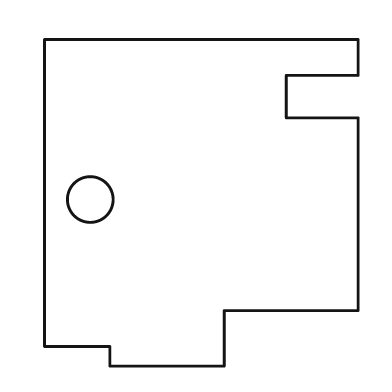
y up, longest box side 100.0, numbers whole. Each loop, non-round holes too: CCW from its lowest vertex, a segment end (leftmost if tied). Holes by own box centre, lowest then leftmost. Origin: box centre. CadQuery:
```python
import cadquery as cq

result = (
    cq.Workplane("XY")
    .moveTo(-28.0, -50.0)
    .lineTo(7.0, -50.0)
    .lineTo(7.0, -33.0)
    .lineTo(48.0, -33.0)
    .lineTo(48.0, 26.0)
    .lineTo(26.0, 26.0)
    .lineTo(26.0, 39.0)
    .lineTo(48.0, 39.0)
    .lineTo(48.0, 50.0)
    .lineTo(-48.0, 50.0)
    .lineTo(-48.0, -44.0)
    .lineTo(-28.0, -44.0)
    .close()
    .moveTo(-34.0, 1.0)
    .circle(7.0)
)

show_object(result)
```